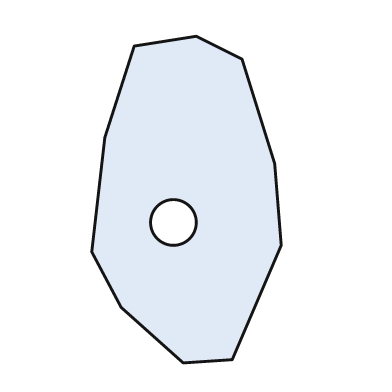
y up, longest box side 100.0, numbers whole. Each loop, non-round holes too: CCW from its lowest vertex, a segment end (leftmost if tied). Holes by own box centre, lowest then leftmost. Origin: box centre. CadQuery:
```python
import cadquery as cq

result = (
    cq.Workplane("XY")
    .moveTo(-1.0, -50.0)
    .lineTo(14.0, -49.0)
    .lineTo(29.0, -14.0)
    .lineTo(27.0, 11.0)
    .lineTo(17.0, 43.0)
    .lineTo(3.0, 50.0)
    .lineTo(-16.0, 47.0)
    .lineTo(-25.0, 19.0)
    .lineTo(-29.0, -16.0)
    .lineTo(-20.0, -33.0)
    .close()
    .moveTo(-4.0, -7.0)
    .circle(7.0)
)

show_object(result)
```